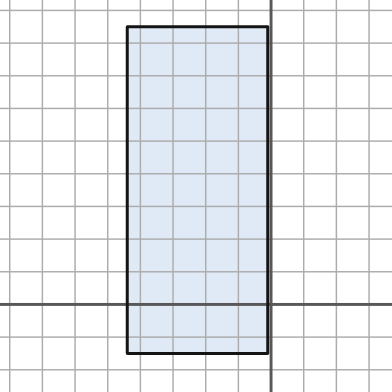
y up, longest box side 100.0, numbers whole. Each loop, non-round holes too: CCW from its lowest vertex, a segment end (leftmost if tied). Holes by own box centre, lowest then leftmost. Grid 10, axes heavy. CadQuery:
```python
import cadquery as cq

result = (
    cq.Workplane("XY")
    .moveTo(-44.0, -15.0)
    .lineTo(-1.0, -15.0)
    .lineTo(-1.0, 85.0)
    .lineTo(-44.0, 85.0)
    .close()
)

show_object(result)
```